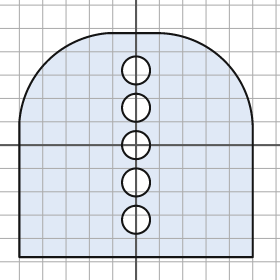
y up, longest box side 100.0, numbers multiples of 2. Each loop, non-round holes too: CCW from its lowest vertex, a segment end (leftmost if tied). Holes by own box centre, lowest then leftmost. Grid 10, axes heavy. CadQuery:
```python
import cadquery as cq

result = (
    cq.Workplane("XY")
    .moveTo(-50.0, -48.0)
    .lineTo(50.0, -48.0)
    .lineTo(50.0, 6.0)
    .threePointArc((38.0, 36.0), (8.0, 48.0))
    .lineTo(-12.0, 48.0)
    .threePointArc((-38.0, 36.0), (-50.0, 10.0))
    .close()
    .moveTo(0.0, -32.0)
    .circle(6.0)
    .moveTo(0.0, -16.0)
    .circle(6.0)
    .moveTo(0.0, 0.0)
    .circle(6.0)
    .moveTo(0.0, 16.0)
    .circle(6.0)
    .moveTo(0.0, 32.0)
    .circle(6.0)
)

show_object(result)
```